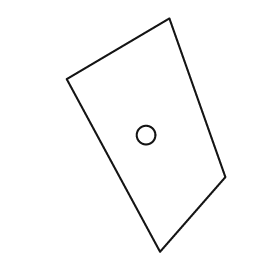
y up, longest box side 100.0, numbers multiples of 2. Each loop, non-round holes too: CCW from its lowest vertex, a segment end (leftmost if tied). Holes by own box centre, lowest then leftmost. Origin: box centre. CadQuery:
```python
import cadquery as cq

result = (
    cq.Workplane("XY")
    .moveTo(6.0, -50.0)
    .lineTo(34.0, -18.0)
    .lineTo(10.0, 50.0)
    .lineTo(-34.0, 24.0)
    .close()
    .moveTo(0.0, 0.0)
    .circle(4.0)
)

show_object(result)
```